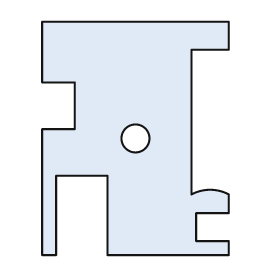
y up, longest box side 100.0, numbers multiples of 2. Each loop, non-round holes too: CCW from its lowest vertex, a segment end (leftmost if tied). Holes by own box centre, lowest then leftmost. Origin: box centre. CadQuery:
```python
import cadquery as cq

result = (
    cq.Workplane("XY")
    .moveTo(-40.0, -50.0)
    .lineTo(-34.0, -50.0)
    .lineTo(-34.0, -16.0)
    .lineTo(-12.0, -16.0)
    .lineTo(-12.0, -50.0)
    .lineTo(40.0, -50.0)
    .lineTo(40.0, -44.0)
    .lineTo(26.0, -44.0)
    .lineTo(26.0, -32.0)
    .lineTo(40.0, -32.0)
    .lineTo(40.0, -24.0)
    .threePointArc((32.0, -22.0), (24.0, -24.0))
    .lineTo(24.0, 38.0)
    .lineTo(40.0, 38.0)
    .lineTo(40.0, 50.0)
    .lineTo(-40.0, 50.0)
    .lineTo(-40.0, 24.0)
    .lineTo(-26.0, 24.0)
    .lineTo(-26.0, 4.0)
    .lineTo(-40.0, 4.0)
    .close()
    .moveTo(0.0, 0.0)
    .circle(6.0)
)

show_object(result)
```